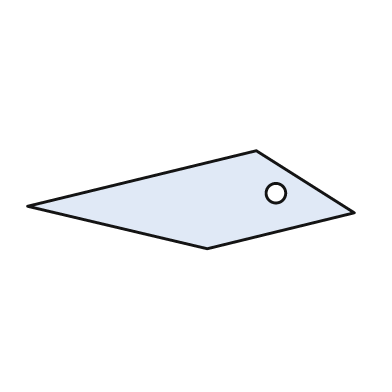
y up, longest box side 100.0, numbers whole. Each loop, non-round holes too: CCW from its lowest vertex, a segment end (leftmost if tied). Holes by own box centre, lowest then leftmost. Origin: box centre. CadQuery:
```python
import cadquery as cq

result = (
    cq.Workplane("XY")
    .moveTo(5.0, -15.0)
    .lineTo(50.0, -4.0)
    .lineTo(20.0, 15.0)
    .lineTo(-50.0, -2.0)
    .close()
    .moveTo(26.0, 2.0)
    .circle(3.0)
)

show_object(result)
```